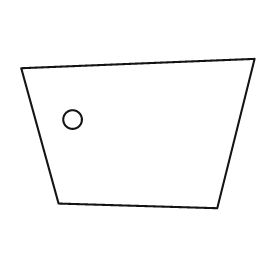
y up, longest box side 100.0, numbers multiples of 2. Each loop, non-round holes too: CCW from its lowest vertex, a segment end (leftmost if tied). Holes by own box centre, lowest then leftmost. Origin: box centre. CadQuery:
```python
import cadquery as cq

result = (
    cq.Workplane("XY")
    .moveTo(34.0, -32.0)
    .lineTo(50.0, 32.0)
    .lineTo(-50.0, 28.0)
    .lineTo(-34.0, -30.0)
    .close()
    .moveTo(-28.0, 6.0)
    .circle(4.0)
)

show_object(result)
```